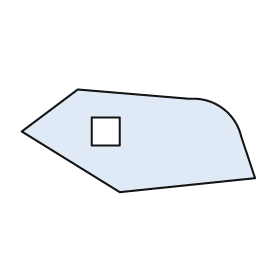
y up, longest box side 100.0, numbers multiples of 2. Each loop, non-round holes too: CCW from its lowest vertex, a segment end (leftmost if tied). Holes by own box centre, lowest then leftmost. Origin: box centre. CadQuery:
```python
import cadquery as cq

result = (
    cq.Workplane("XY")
    .moveTo(-8.0, -22.0)
    .lineTo(50.0, -16.0)
    .lineTo(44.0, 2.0)
    .threePointArc((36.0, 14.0), (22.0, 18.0))
    .lineTo(-26.0, 22.0)
    .lineTo(-50.0, 4.0)
    .close()
    .moveTo(-20.0, -2.0)
    .lineTo(-8.0, -2.0)
    .lineTo(-8.0, 10.0)
    .lineTo(-20.0, 10.0)
    .close()
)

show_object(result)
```